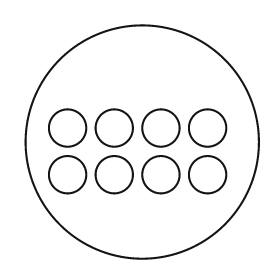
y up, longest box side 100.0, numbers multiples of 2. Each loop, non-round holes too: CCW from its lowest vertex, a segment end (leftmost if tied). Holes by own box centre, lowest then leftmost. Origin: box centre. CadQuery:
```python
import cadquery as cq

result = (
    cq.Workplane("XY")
    .moveTo(0.0, 0.0)
    .circle(50.0)
    .moveTo(-32.0, -14.0)
    .circle(8.0)
    .moveTo(-12.0, -14.0)
    .circle(8.0)
    .moveTo(8.0, -14.0)
    .circle(8.0)
    .moveTo(28.0, -14.0)
    .circle(8.0)
    .moveTo(-32.0, 6.0)
    .circle(8.0)
    .moveTo(-12.0, 6.0)
    .circle(8.0)
    .moveTo(8.0, 6.0)
    .circle(8.0)
    .moveTo(28.0, 6.0)
    .circle(8.0)
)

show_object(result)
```